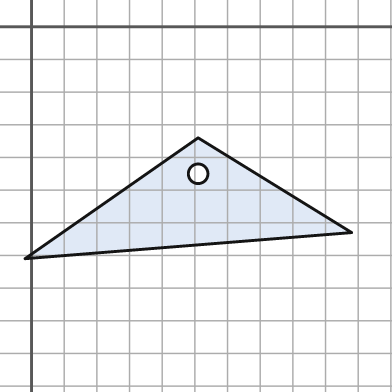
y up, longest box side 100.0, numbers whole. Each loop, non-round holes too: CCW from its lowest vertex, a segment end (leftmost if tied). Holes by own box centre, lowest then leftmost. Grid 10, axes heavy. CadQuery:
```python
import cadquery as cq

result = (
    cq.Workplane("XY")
    .moveTo(-2.0, -71.0)
    .lineTo(98.0, -63.0)
    .lineTo(51.0, -34.0)
    .close()
    .moveTo(51.0, -45.0)
    .circle(3.0)
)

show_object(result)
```